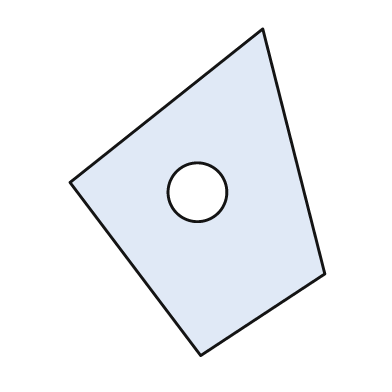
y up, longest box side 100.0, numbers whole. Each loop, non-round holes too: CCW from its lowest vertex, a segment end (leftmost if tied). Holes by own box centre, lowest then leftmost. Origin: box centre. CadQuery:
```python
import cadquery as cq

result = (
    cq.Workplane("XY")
    .moveTo(1.0, -50.0)
    .lineTo(39.0, -25.0)
    .lineTo(20.0, 50.0)
    .lineTo(-39.0, 3.0)
    .close()
    .moveTo(0.0, 0.0)
    .circle(9.0)
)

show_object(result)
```